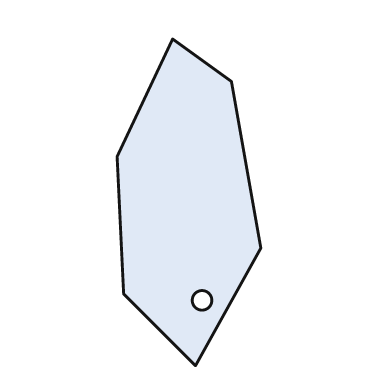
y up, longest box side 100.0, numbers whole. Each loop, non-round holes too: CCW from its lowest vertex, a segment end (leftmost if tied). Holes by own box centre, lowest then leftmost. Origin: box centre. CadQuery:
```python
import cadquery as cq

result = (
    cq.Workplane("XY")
    .moveTo(2.0, -50.0)
    .lineTo(22.0, -14.0)
    .lineTo(13.0, 37.0)
    .lineTo(-5.0, 50.0)
    .lineTo(-22.0, 14.0)
    .lineTo(-20.0, -28.0)
    .close()
    .moveTo(4.0, -30.0)
    .circle(3.0)
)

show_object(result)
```